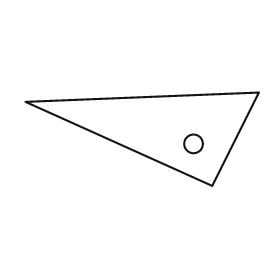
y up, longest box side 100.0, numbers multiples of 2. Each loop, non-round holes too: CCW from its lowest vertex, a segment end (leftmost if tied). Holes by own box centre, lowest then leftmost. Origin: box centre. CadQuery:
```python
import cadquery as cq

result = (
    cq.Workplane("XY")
    .moveTo(30.0, -20.0)
    .lineTo(50.0, 20.0)
    .lineTo(-50.0, 16.0)
    .close()
    .moveTo(22.0, -2.0)
    .circle(4.0)
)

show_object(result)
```